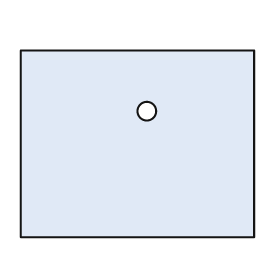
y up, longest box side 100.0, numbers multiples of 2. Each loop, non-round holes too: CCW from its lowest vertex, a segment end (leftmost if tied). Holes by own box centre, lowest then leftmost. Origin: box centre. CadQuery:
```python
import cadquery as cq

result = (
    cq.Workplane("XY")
    .moveTo(-50.0, -40.0)
    .lineTo(50.0, -40.0)
    .lineTo(50.0, 40.0)
    .lineTo(-50.0, 40.0)
    .close()
    .moveTo(4.0, 14.0)
    .circle(4.0)
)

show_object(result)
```